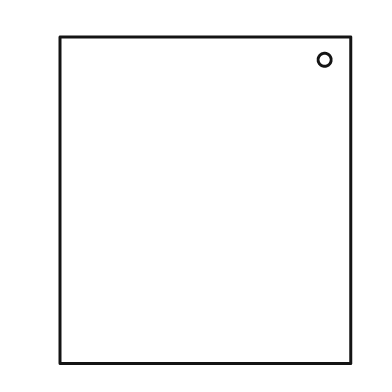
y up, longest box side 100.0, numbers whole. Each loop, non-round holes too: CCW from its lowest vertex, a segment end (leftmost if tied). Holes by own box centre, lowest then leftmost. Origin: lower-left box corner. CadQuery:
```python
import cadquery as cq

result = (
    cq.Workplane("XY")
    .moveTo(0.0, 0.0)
    .lineTo(89.0, 0.0)
    .lineTo(89.0, 100.0)
    .lineTo(0.0, 100.0)
    .close()
    .moveTo(81.0, 93.0)
    .circle(2.0)
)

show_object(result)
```